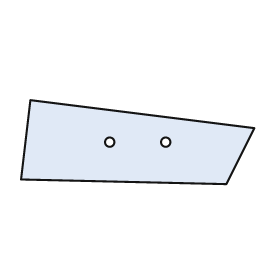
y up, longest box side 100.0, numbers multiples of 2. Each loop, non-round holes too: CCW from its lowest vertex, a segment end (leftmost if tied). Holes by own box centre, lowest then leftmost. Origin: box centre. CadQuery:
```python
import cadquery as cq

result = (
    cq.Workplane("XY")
    .moveTo(38.0, -18.0)
    .lineTo(50.0, 6.0)
    .lineTo(-46.0, 18.0)
    .lineTo(-50.0, -16.0)
    .close()
    .moveTo(-12.0, 0.0)
    .circle(2.0)
    .moveTo(12.0, 0.0)
    .circle(2.0)
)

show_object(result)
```